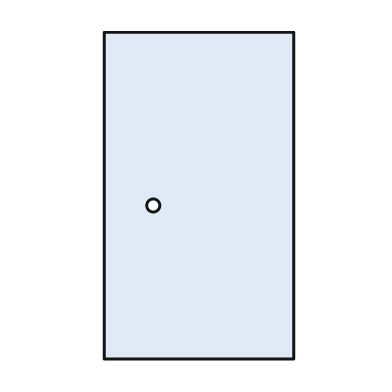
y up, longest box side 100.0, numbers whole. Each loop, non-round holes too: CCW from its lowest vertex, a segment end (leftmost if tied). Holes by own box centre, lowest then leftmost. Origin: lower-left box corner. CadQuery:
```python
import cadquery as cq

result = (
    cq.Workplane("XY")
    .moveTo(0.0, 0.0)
    .lineTo(58.0, 0.0)
    .lineTo(58.0, 100.0)
    .lineTo(0.0, 100.0)
    .close()
    .moveTo(15.0, 47.0)
    .circle(2.0)
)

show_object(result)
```